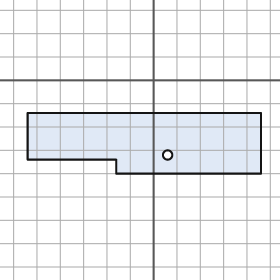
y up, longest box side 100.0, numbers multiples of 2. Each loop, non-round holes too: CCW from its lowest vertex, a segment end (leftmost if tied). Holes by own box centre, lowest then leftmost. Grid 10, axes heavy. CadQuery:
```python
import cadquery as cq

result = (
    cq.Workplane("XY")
    .moveTo(-16.0, -40.0)
    .lineTo(46.0, -40.0)
    .lineTo(46.0, -14.0)
    .lineTo(-54.0, -14.0)
    .lineTo(-54.0, -34.0)
    .lineTo(-16.0, -34.0)
    .close()
    .moveTo(6.0, -32.0)
    .circle(2.0)
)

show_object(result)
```